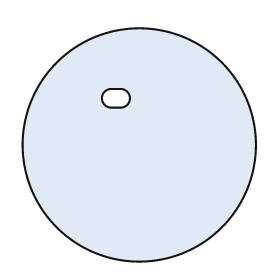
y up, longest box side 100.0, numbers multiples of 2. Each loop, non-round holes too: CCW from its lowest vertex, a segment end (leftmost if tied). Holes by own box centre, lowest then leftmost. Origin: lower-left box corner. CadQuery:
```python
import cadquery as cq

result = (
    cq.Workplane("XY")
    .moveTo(50.0, 50.0)
    .circle(50.0)
    .moveTo(38.0, 66.0)
    .lineTo(42.0, 66.0)
    .threePointArc((46.0, 70.0), (42.0, 74.0))
    .lineTo(38.0, 74.0)
    .threePointArc((34.0, 70.0), (38.0, 66.0))
    .close()
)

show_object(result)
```